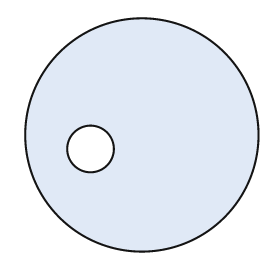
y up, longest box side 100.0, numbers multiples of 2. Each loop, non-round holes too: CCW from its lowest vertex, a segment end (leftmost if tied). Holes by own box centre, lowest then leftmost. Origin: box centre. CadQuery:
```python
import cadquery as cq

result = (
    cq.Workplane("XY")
    .moveTo(0.0, 0.0)
    .circle(50.0)
    .moveTo(-22.0, -6.0)
    .circle(10.0)
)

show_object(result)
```